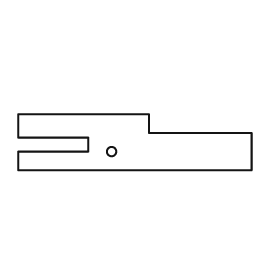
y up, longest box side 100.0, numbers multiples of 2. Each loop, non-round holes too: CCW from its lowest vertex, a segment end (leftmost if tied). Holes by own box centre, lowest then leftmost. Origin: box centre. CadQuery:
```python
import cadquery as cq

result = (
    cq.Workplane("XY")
    .moveTo(-50.0, -12.0)
    .lineTo(50.0, -12.0)
    .lineTo(50.0, 4.0)
    .lineTo(6.0, 4.0)
    .lineTo(6.0, 12.0)
    .lineTo(-50.0, 12.0)
    .lineTo(-50.0, 2.0)
    .lineTo(-20.0, 2.0)
    .lineTo(-20.0, -4.0)
    .lineTo(-50.0, -4.0)
    .close()
    .moveTo(-10.0, -4.0)
    .circle(2.0)
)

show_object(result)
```